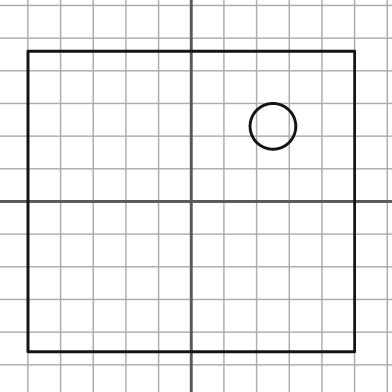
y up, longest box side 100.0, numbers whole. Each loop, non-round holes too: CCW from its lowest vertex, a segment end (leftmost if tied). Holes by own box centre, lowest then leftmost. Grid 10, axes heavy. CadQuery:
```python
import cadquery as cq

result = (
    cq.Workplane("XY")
    .moveTo(-50.0, -46.0)
    .lineTo(50.0, -46.0)
    .lineTo(50.0, 46.0)
    .lineTo(-50.0, 46.0)
    .close()
    .moveTo(25.0, 23.0)
    .circle(7.0)
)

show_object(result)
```